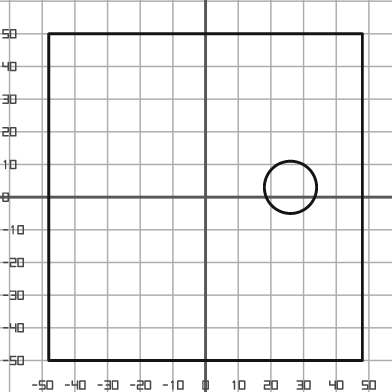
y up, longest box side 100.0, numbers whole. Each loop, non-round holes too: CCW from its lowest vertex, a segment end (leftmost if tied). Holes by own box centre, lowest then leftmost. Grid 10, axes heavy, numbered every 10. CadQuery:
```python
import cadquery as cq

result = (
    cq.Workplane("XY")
    .moveTo(-48.0, -50.0)
    .lineTo(48.0, -50.0)
    .lineTo(48.0, 50.0)
    .lineTo(-48.0, 50.0)
    .close()
    .moveTo(26.0, 3.0)
    .circle(8.0)
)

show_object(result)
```